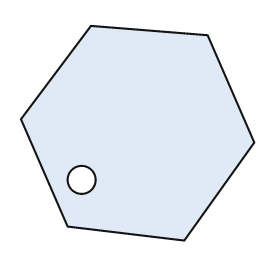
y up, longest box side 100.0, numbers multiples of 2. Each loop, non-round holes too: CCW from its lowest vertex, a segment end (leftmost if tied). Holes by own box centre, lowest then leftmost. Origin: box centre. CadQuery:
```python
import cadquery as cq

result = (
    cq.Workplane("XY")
    .moveTo(20.0, -46.0)
    .lineTo(50.0, -4.0)
    .lineTo(30.0, 42.0)
    .lineTo(-20.0, 46.0)
    .lineTo(-50.0, 6.0)
    .lineTo(-30.0, -40.0)
    .close()
    .moveTo(-24.0, -20.0)
    .circle(6.0)
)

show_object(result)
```